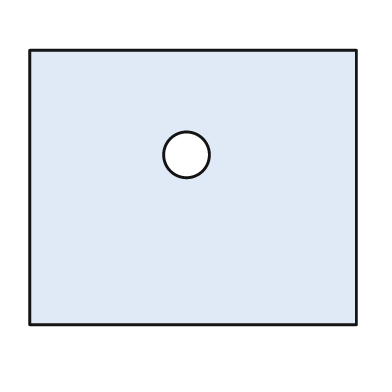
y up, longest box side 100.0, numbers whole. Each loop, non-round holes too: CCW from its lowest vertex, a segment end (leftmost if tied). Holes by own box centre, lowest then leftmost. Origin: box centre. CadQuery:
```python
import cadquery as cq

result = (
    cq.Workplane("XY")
    .moveTo(-50.0, -42.0)
    .lineTo(50.0, -42.0)
    .lineTo(50.0, 42.0)
    .lineTo(-50.0, 42.0)
    .close()
    .moveTo(-2.0, 10.0)
    .circle(7.0)
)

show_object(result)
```